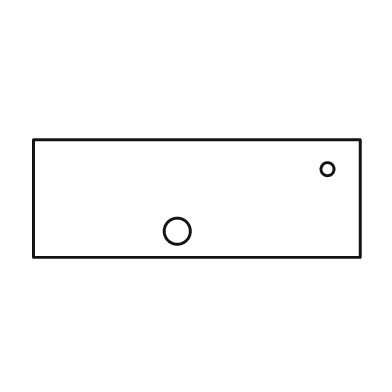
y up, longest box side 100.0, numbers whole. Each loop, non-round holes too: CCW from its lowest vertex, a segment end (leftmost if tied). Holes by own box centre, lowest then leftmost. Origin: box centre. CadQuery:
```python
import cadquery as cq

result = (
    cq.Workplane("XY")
    .moveTo(-50.0, -18.0)
    .lineTo(50.0, -18.0)
    .lineTo(50.0, 18.0)
    .lineTo(-50.0, 18.0)
    .close()
    .moveTo(-6.0, -10.0)
    .circle(4.0)
    .moveTo(40.0, 9.0)
    .circle(2.0)
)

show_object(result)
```